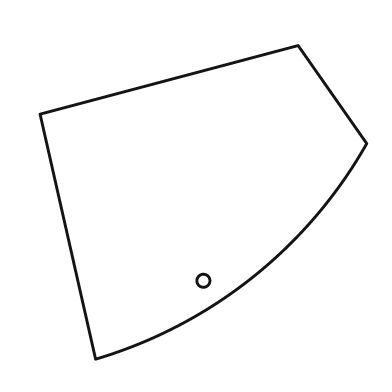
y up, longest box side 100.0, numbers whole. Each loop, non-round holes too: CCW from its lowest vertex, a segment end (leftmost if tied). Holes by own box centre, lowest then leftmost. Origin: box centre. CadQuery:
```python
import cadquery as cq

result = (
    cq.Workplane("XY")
    .moveTo(-33.0, -48.0)
    .threePointArc((15.0, -23.0), (50.0, 18.0))
    .lineTo(29.0, 48.0)
    .lineTo(-50.0, 27.0)
    .close()
    .moveTo(0.0, -24.0)
    .circle(2.0)
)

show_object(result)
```